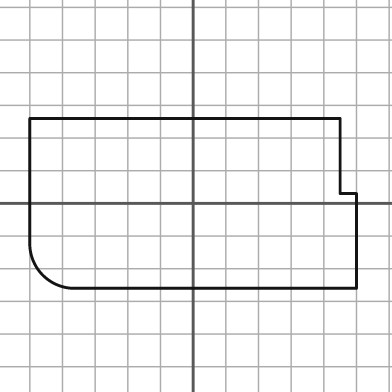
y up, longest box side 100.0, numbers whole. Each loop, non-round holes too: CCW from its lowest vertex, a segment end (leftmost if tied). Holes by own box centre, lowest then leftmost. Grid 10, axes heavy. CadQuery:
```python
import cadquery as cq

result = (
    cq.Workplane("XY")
    .moveTo(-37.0, -26.0)
    .lineTo(50.0, -26.0)
    .lineTo(50.0, 3.0)
    .lineTo(45.0, 3.0)
    .lineTo(45.0, 26.0)
    .lineTo(-50.0, 26.0)
    .lineTo(-50.0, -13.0)
    .threePointArc((-46.0, -22.0), (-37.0, -26.0))
    .close()
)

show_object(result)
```